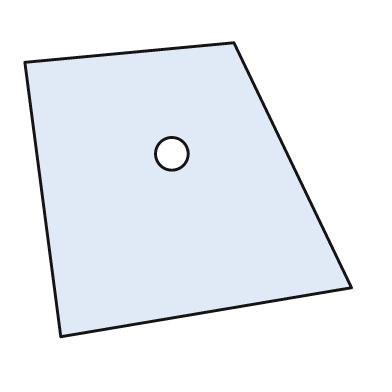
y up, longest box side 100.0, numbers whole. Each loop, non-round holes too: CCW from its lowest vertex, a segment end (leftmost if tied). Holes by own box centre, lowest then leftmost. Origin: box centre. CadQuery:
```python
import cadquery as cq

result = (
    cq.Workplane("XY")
    .moveTo(-39.0, -45.0)
    .lineTo(50.0, -30.0)
    .lineTo(14.0, 45.0)
    .lineTo(-50.0, 39.0)
    .close()
    .moveTo(-5.0, 11.0)
    .circle(5.0)
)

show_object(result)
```